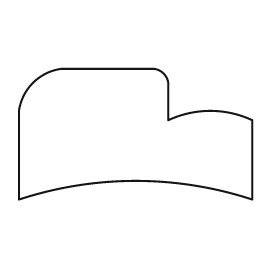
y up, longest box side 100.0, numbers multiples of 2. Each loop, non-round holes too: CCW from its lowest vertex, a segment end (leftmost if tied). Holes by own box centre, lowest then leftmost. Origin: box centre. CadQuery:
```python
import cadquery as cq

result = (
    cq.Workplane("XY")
    .moveTo(-50.0, -28.0)
    .threePointArc((0.0, -20.0), (50.0, -28.0))
    .lineTo(50.0, 6.0)
    .threePointArc((32.0, 10.0), (14.0, 6.0))
    .lineTo(14.0, 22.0)
    .threePointArc((12.0, 26.0), (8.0, 28.0))
    .lineTo(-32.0, 28.0)
    .threePointArc((-44.0, 22.0), (-50.0, 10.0))
    .close()
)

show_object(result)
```